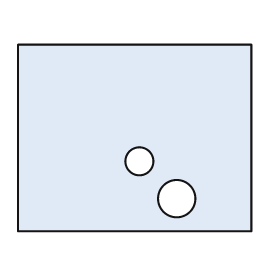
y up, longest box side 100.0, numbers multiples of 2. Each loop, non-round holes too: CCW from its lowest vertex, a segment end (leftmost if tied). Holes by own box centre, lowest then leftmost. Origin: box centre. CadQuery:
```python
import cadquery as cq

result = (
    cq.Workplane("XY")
    .moveTo(-50.0, -40.0)
    .lineTo(50.0, -40.0)
    .lineTo(50.0, 40.0)
    .lineTo(-50.0, 40.0)
    .close()
    .moveTo(18.0, -26.0)
    .circle(8.0)
    .moveTo(2.0, -10.0)
    .circle(6.0)
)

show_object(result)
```